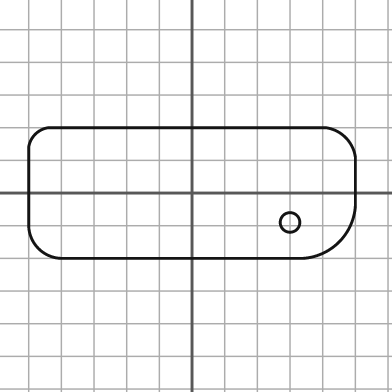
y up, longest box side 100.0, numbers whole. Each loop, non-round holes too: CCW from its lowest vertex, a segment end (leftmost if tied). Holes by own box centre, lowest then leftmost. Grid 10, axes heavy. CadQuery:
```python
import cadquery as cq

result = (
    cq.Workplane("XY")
    .moveTo(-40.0, -20.0)
    .lineTo(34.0, -20.0)
    .threePointArc((45.0, -15.0), (50.0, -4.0))
    .lineTo(50.0, 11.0)
    .threePointArc((47.0, 17.0), (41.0, 20.0))
    .lineTo(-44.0, 20.0)
    .threePointArc((-48.0, 18.0), (-50.0, 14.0))
    .lineTo(-50.0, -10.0)
    .threePointArc((-47.0, -17.0), (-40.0, -20.0))
    .close()
    .moveTo(30.0, -9.0)
    .circle(3.0)
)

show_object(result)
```